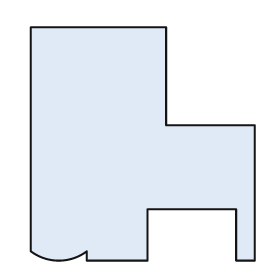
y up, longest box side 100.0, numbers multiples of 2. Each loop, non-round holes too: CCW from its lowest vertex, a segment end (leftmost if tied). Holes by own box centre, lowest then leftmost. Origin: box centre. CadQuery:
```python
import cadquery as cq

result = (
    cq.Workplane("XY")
    .moveTo(-24.0, -50.0)
    .lineTo(2.0, -50.0)
    .lineTo(2.0, -28.0)
    .lineTo(40.0, -28.0)
    .lineTo(40.0, -50.0)
    .lineTo(48.0, -50.0)
    .lineTo(48.0, 8.0)
    .lineTo(10.0, 8.0)
    .lineTo(10.0, 50.0)
    .lineTo(-48.0, 50.0)
    .lineTo(-48.0, -46.0)
    .threePointArc((-36.0, -50.0), (-24.0, -46.0))
    .close()
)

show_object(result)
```